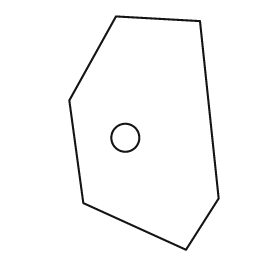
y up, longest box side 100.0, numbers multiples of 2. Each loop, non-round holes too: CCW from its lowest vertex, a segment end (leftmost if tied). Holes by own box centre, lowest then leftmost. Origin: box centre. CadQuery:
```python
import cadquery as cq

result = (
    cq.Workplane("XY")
    .moveTo(18.0, -50.0)
    .lineTo(32.0, -28.0)
    .lineTo(24.0, 48.0)
    .lineTo(-12.0, 50.0)
    .lineTo(-32.0, 14.0)
    .lineTo(-26.0, -30.0)
    .close()
    .moveTo(-8.0, -2.0)
    .circle(6.0)
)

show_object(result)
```